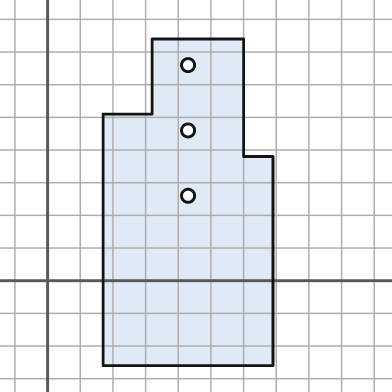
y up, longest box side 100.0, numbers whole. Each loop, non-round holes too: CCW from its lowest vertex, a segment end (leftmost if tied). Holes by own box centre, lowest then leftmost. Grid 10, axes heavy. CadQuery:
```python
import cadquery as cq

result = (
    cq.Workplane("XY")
    .moveTo(17.0, -26.0)
    .lineTo(69.0, -26.0)
    .lineTo(69.0, 38.0)
    .lineTo(60.0, 38.0)
    .lineTo(60.0, 74.0)
    .lineTo(32.0, 74.0)
    .lineTo(32.0, 51.0)
    .lineTo(17.0, 51.0)
    .close()
    .moveTo(43.0, 26.0)
    .circle(2.0)
    .moveTo(43.0, 46.0)
    .circle(2.0)
    .moveTo(43.0, 66.0)
    .circle(2.0)
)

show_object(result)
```